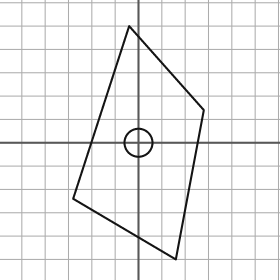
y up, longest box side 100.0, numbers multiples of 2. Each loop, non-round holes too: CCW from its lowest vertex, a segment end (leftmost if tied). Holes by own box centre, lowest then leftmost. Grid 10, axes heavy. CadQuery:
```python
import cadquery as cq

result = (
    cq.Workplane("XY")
    .moveTo(16.0, -50.0)
    .lineTo(28.0, 14.0)
    .lineTo(-4.0, 50.0)
    .lineTo(-28.0, -24.0)
    .close()
    .moveTo(0.0, 0.0)
    .circle(6.0)
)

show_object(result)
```